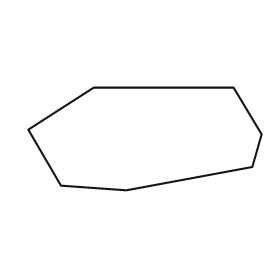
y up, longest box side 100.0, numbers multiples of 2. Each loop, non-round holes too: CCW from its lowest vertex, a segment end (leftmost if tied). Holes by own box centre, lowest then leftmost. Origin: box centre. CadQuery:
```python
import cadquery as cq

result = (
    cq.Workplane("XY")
    .moveTo(-8.0, -22.0)
    .lineTo(46.0, -12.0)
    .lineTo(50.0, 2.0)
    .lineTo(38.0, 22.0)
    .lineTo(-22.0, 22.0)
    .lineTo(-50.0, 4.0)
    .lineTo(-36.0, -20.0)
    .close()
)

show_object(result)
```